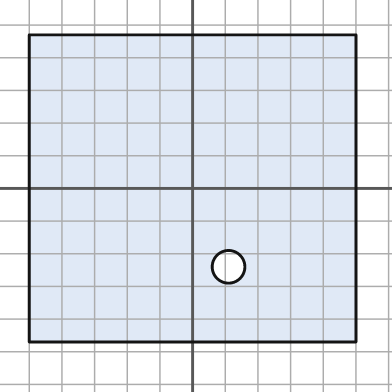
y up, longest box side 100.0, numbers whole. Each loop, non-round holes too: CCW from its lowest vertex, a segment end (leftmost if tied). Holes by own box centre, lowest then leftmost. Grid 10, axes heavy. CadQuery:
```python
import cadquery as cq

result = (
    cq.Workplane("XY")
    .moveTo(-50.0, -47.0)
    .lineTo(50.0, -47.0)
    .lineTo(50.0, 47.0)
    .lineTo(-50.0, 47.0)
    .close()
    .moveTo(11.0, -24.0)
    .circle(5.0)
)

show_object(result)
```